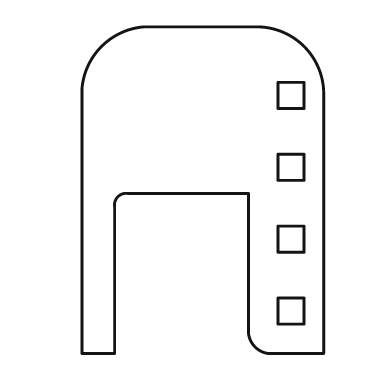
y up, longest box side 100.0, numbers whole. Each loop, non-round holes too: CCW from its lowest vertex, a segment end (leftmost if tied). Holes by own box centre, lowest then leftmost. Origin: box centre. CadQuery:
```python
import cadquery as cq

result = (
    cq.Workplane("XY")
    .moveTo(-37.0, -50.0)
    .lineTo(-27.0, -50.0)
    .lineTo(-27.0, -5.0)
    .threePointArc((-26.0, -2.0), (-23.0, -1.0))
    .lineTo(14.0, -1.0)
    .lineTo(14.0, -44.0)
    .threePointArc((16.0, -48.0), (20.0, -50.0))
    .lineTo(37.0, -50.0)
    .lineTo(37.0, 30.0)
    .threePointArc((31.0, 44.0), (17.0, 50.0))
    .lineTo(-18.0, 50.0)
    .threePointArc((-31.0, 44.0), (-37.0, 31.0))
    .close()
    .moveTo(23.0, -41.0)
    .lineTo(31.0, -41.0)
    .lineTo(31.0, -33.0)
    .lineTo(23.0, -33.0)
    .close()
    .moveTo(23.0, -19.0)
    .lineTo(31.0, -19.0)
    .lineTo(31.0, -11.0)
    .lineTo(23.0, -11.0)
    .close()
    .moveTo(23.0, 3.0)
    .lineTo(31.0, 3.0)
    .lineTo(31.0, 11.0)
    .lineTo(23.0, 11.0)
    .close()
    .moveTo(23.0, 25.0)
    .lineTo(31.0, 25.0)
    .lineTo(31.0, 33.0)
    .lineTo(23.0, 33.0)
    .close()
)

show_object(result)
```